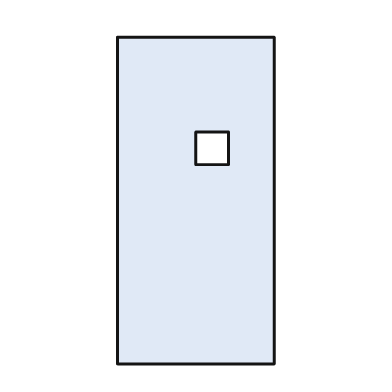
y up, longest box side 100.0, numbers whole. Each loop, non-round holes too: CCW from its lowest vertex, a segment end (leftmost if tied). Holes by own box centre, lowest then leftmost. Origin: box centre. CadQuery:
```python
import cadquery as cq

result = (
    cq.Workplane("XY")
    .moveTo(-24.0, -50.0)
    .lineTo(24.0, -50.0)
    .lineTo(24.0, 50.0)
    .lineTo(-24.0, 50.0)
    .close()
    .moveTo(0.0, 11.0)
    .lineTo(10.0, 11.0)
    .lineTo(10.0, 21.0)
    .lineTo(0.0, 21.0)
    .close()
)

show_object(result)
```